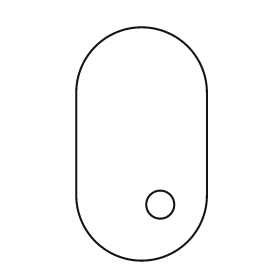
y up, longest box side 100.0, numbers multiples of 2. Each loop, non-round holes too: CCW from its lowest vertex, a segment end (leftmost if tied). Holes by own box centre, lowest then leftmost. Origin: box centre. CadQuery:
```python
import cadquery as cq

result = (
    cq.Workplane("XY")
    .moveTo(-28.0, -22.0)
    .threePointArc((0.0, -50.0), (28.0, -22.0))
    .lineTo(28.0, 22.0)
    .threePointArc((0.0, 50.0), (-28.0, 22.0))
    .close()
    .moveTo(8.0, -26.0)
    .circle(6.0)
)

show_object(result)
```